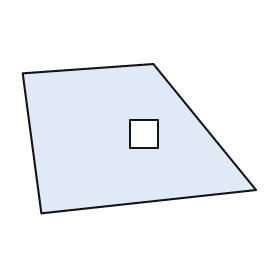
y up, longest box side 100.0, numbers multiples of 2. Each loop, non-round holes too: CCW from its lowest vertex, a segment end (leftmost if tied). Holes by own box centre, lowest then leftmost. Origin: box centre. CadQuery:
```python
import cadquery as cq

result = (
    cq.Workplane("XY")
    .moveTo(-42.0, -32.0)
    .lineTo(50.0, -22.0)
    .lineTo(6.0, 32.0)
    .lineTo(-50.0, 28.0)
    .close()
    .moveTo(-4.0, -4.0)
    .lineTo(8.0, -4.0)
    .lineTo(8.0, 8.0)
    .lineTo(-4.0, 8.0)
    .close()
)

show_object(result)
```